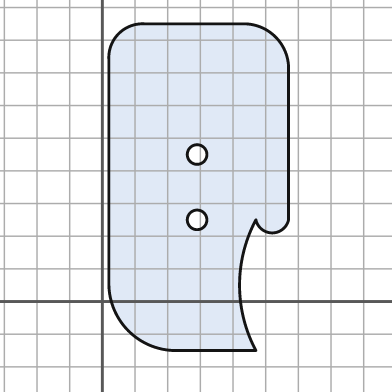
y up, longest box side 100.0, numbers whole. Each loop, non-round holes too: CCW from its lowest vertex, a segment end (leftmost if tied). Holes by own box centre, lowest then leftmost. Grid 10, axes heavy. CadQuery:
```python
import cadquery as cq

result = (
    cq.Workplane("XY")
    .moveTo(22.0, -15.0)
    .lineTo(47.0, -15.0)
    .threePointArc((42.0, 5.0), (47.0, 25.0))
    .threePointArc((52.0, 21.0), (57.0, 25.0))
    .lineTo(57.0, 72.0)
    .threePointArc((53.0, 81.0), (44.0, 85.0))
    .lineTo(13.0, 85.0)
    .threePointArc((5.0, 82.0), (2.0, 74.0))
    .lineTo(2.0, 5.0)
    .threePointArc((8.0, -9.0), (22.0, -15.0))
    .close()
    .moveTo(29.0, 25.0)
    .circle(3.0)
    .moveTo(29.0, 45.0)
    .circle(3.0)
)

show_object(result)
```